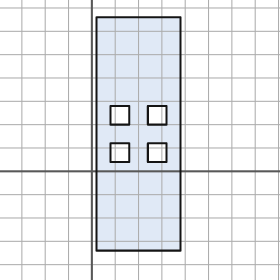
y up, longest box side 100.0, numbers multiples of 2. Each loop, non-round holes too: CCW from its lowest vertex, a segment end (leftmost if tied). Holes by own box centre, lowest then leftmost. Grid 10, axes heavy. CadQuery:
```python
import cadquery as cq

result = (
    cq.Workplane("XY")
    .moveTo(2.0, -34.0)
    .lineTo(38.0, -34.0)
    .lineTo(38.0, 66.0)
    .lineTo(2.0, 66.0)
    .close()
    .moveTo(8.0, 4.0)
    .lineTo(16.0, 4.0)
    .lineTo(16.0, 12.0)
    .lineTo(8.0, 12.0)
    .close()
    .moveTo(24.0, 4.0)
    .lineTo(32.0, 4.0)
    .lineTo(32.0, 12.0)
    .lineTo(24.0, 12.0)
    .close()
    .moveTo(8.0, 20.0)
    .lineTo(16.0, 20.0)
    .lineTo(16.0, 28.0)
    .lineTo(8.0, 28.0)
    .close()
    .moveTo(24.0, 20.0)
    .lineTo(32.0, 20.0)
    .lineTo(32.0, 28.0)
    .lineTo(24.0, 28.0)
    .close()
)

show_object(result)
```